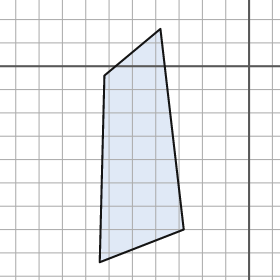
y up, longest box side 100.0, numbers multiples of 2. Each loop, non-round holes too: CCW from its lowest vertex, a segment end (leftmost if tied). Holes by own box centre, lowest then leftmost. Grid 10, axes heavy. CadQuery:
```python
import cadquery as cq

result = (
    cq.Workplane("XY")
    .moveTo(-64.0, -84.0)
    .lineTo(-28.0, -70.0)
    .lineTo(-38.0, 16.0)
    .lineTo(-62.0, -4.0)
    .close()
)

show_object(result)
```